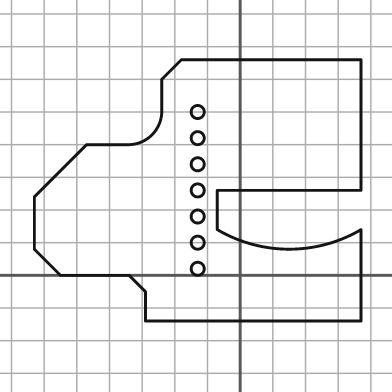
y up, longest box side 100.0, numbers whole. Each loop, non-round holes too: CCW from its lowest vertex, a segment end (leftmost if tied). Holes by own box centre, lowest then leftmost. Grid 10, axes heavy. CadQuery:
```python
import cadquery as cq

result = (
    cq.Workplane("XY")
    .moveTo(-29.0, -14.0)
    .lineTo(37.0, -14.0)
    .lineTo(37.0, 14.0)
    .threePointArc((15.0, 8.0), (-7.0, 14.0))
    .lineTo(-7.0, 26.0)
    .lineTo(37.0, 26.0)
    .lineTo(37.0, 66.0)
    .lineTo(-18.0, 66.0)
    .lineTo(-24.0, 60.0)
    .lineTo(-24.0, 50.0)
    .threePointArc((-27.0, 43.0), (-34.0, 40.0))
    .lineTo(-47.0, 40.0)
    .lineTo(-63.0, 24.0)
    .lineTo(-63.0, 8.0)
    .lineTo(-55.0, 0.0)
    .lineTo(-34.0, 0.0)
    .lineTo(-29.0, -5.0)
    .close()
    .moveTo(-13.0, 2.0)
    .circle(2.0)
    .moveTo(-13.0, 10.0)
    .circle(2.0)
    .moveTo(-13.0, 18.0)
    .circle(2.0)
    .moveTo(-13.0, 26.0)
    .circle(2.0)
    .moveTo(-13.0, 34.0)
    .circle(2.0)
    .moveTo(-13.0, 42.0)
    .circle(2.0)
    .moveTo(-13.0, 50.0)
    .circle(2.0)
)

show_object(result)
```